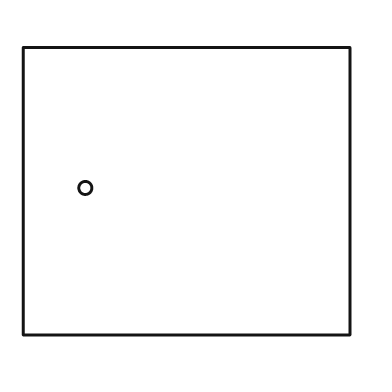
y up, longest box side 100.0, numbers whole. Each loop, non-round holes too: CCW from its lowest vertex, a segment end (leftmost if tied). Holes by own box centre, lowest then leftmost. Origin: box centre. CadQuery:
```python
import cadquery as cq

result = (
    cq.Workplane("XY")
    .moveTo(-50.0, -44.0)
    .lineTo(50.0, -44.0)
    .lineTo(50.0, 44.0)
    .lineTo(-50.0, 44.0)
    .close()
    .moveTo(-31.0, 1.0)
    .circle(2.0)
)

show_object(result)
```